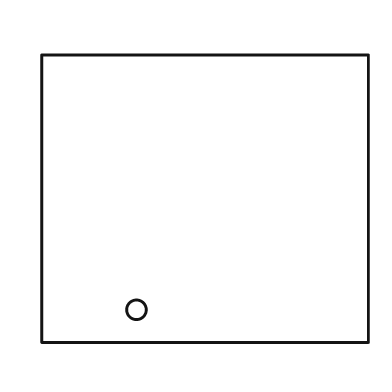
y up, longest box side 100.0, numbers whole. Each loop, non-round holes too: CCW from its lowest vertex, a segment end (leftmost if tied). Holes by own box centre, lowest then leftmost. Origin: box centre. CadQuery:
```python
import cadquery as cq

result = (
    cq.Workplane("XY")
    .moveTo(-50.0, -44.0)
    .lineTo(50.0, -44.0)
    .lineTo(50.0, 44.0)
    .lineTo(-50.0, 44.0)
    .close()
    .moveTo(-21.0, -34.0)
    .circle(3.0)
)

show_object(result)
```